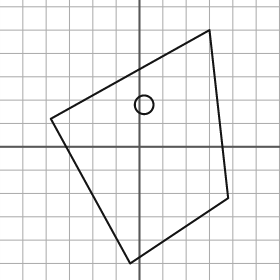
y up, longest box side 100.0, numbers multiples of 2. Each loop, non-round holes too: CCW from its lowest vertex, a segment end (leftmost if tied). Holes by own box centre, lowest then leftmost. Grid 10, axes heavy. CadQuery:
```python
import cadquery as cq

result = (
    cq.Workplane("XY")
    .moveTo(-4.0, -50.0)
    .lineTo(38.0, -22.0)
    .lineTo(30.0, 50.0)
    .lineTo(-38.0, 12.0)
    .close()
    .moveTo(2.0, 18.0)
    .circle(4.0)
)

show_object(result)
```